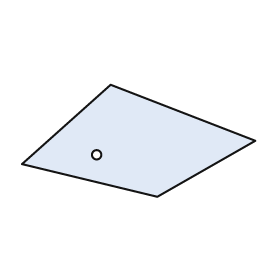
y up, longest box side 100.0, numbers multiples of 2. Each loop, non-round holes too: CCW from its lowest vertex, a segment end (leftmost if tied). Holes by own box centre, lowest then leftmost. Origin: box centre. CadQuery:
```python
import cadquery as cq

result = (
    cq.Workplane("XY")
    .moveTo(8.0, -24.0)
    .lineTo(50.0, 0.0)
    .lineTo(-12.0, 24.0)
    .lineTo(-50.0, -10.0)
    .close()
    .moveTo(-18.0, -6.0)
    .circle(2.0)
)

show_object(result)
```